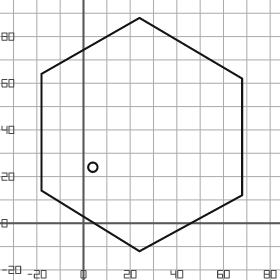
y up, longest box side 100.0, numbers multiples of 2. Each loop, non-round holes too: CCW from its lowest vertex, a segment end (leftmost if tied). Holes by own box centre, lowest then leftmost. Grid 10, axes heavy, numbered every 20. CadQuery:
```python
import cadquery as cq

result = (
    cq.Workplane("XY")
    .moveTo(24.0, -12.0)
    .lineTo(68.0, 12.0)
    .lineTo(68.0, 62.0)
    .lineTo(24.0, 88.0)
    .lineTo(-18.0, 64.0)
    .lineTo(-18.0, 14.0)
    .close()
    .moveTo(4.0, 24.0)
    .circle(2.0)
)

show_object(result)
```